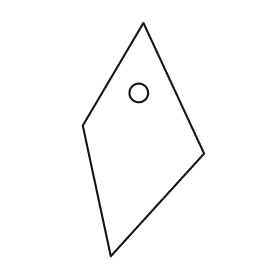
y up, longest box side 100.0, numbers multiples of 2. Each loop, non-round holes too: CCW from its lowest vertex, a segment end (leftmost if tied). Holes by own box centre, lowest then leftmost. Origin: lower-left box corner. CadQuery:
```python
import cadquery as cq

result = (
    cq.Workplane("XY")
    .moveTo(12.0, 0.0)
    .lineTo(52.0, 44.0)
    .lineTo(26.0, 100.0)
    .lineTo(0.0, 56.0)
    .close()
    .moveTo(24.0, 70.0)
    .circle(4.0)
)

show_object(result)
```